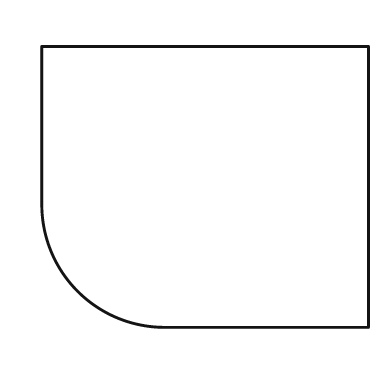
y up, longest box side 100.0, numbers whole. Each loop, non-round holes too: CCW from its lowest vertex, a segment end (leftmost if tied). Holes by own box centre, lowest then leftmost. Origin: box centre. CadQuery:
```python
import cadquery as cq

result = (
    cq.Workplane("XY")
    .moveTo(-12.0, -43.0)
    .lineTo(50.0, -43.0)
    .lineTo(50.0, 43.0)
    .lineTo(-50.0, 43.0)
    .lineTo(-50.0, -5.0)
    .threePointArc((-39.0, -32.0), (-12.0, -43.0))
    .close()
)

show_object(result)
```